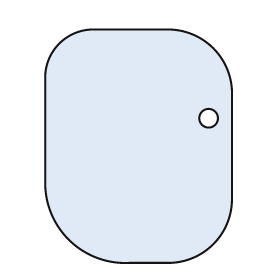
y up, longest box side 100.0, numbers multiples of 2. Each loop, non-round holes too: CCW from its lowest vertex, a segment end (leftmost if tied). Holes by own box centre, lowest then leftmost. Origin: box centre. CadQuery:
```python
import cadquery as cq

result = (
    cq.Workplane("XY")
    .moveTo(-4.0, -50.0)
    .lineTo(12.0, -50.0)
    .threePointArc((32.0, -42.0), (40.0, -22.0))
    .lineTo(40.0, 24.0)
    .threePointArc((32.0, 42.0), (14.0, 50.0))
    .lineTo(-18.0, 50.0)
    .threePointArc((-34.0, 44.0), (-40.0, 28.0))
    .lineTo(-40.0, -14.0)
    .threePointArc((-30.0, -40.0), (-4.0, -50.0))
    .close()
    .moveTo(30.0, 12.0)
    .circle(4.0)
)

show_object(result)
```